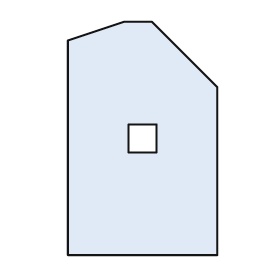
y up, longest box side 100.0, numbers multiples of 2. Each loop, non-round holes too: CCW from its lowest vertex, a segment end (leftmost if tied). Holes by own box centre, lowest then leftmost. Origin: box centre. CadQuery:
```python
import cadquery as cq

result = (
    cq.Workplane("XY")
    .moveTo(-32.0, -50.0)
    .lineTo(32.0, -50.0)
    .lineTo(32.0, 22.0)
    .lineTo(4.0, 50.0)
    .lineTo(-8.0, 50.0)
    .lineTo(-32.0, 42.0)
    .close()
    .moveTo(-6.0, -6.0)
    .lineTo(6.0, -6.0)
    .lineTo(6.0, 6.0)
    .lineTo(-6.0, 6.0)
    .close()
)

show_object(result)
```